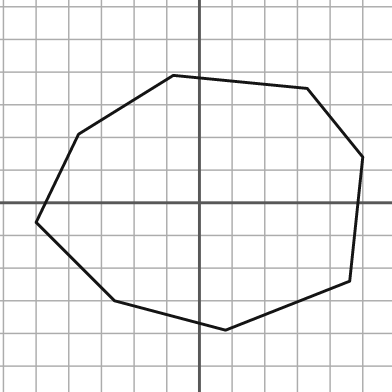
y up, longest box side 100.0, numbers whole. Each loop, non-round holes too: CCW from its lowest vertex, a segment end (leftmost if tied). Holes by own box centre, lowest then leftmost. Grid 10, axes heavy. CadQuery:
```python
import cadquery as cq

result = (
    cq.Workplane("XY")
    .moveTo(8.0, -39.0)
    .lineTo(46.0, -24.0)
    .lineTo(50.0, 14.0)
    .lineTo(33.0, 35.0)
    .lineTo(-8.0, 39.0)
    .lineTo(-37.0, 21.0)
    .lineTo(-50.0, -6.0)
    .lineTo(-26.0, -30.0)
    .close()
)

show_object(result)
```